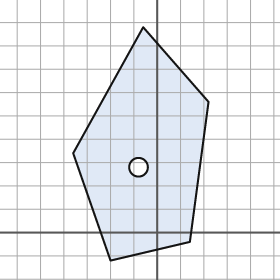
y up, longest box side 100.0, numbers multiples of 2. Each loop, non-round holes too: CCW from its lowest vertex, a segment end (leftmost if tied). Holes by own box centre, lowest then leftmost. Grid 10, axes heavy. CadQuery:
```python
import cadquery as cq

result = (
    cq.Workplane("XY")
    .moveTo(-20.0, -12.0)
    .lineTo(14.0, -4.0)
    .lineTo(22.0, 56.0)
    .lineTo(-6.0, 88.0)
    .lineTo(-36.0, 34.0)
    .close()
    .moveTo(-8.0, 28.0)
    .circle(4.0)
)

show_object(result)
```